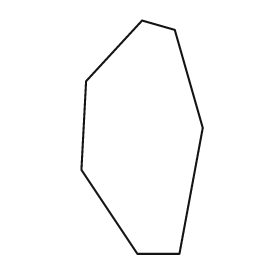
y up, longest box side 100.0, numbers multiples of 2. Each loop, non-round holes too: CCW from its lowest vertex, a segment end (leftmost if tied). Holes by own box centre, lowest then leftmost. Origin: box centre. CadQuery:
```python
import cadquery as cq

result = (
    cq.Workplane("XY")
    .moveTo(-2.0, -50.0)
    .lineTo(16.0, -50.0)
    .lineTo(26.0, 4.0)
    .lineTo(14.0, 46.0)
    .lineTo(0.0, 50.0)
    .lineTo(-24.0, 24.0)
    .lineTo(-26.0, -14.0)
    .close()
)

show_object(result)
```